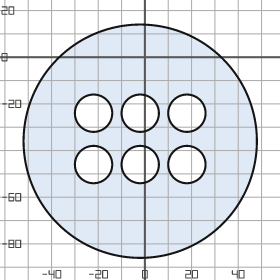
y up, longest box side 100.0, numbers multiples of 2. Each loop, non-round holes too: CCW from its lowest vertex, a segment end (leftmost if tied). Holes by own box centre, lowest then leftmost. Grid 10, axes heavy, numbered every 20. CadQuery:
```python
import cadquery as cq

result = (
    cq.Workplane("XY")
    .moveTo(-2.0, -36.0)
    .circle(50.0)
    .moveTo(-22.0, -46.0)
    .circle(8.0)
    .moveTo(-2.0, -46.0)
    .circle(8.0)
    .moveTo(18.0, -46.0)
    .circle(8.0)
    .moveTo(-22.0, -24.0)
    .circle(8.0)
    .moveTo(-2.0, -24.0)
    .circle(8.0)
    .moveTo(18.0, -24.0)
    .circle(8.0)
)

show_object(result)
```